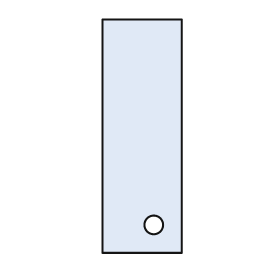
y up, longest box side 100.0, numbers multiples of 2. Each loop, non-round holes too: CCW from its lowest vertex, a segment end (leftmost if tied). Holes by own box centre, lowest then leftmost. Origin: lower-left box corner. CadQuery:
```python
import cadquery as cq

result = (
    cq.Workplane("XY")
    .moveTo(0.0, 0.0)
    .lineTo(34.0, 0.0)
    .lineTo(34.0, 100.0)
    .lineTo(0.0, 100.0)
    .close()
    .moveTo(22.0, 12.0)
    .circle(4.0)
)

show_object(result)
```